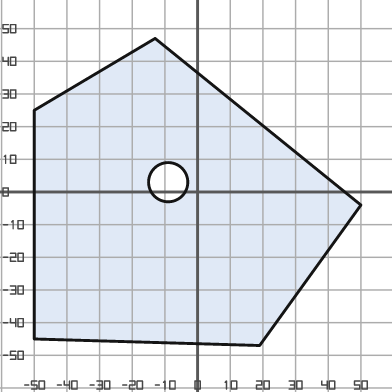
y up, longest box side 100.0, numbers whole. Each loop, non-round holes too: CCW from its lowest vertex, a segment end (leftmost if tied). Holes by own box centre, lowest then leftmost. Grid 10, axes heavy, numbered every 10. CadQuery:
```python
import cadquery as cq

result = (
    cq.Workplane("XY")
    .moveTo(19.0, -47.0)
    .lineTo(50.0, -4.0)
    .lineTo(-13.0, 47.0)
    .lineTo(-50.0, 25.0)
    .lineTo(-50.0, -45.0)
    .close()
    .moveTo(-9.0, 3.0)
    .circle(6.0)
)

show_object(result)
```